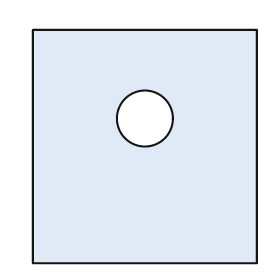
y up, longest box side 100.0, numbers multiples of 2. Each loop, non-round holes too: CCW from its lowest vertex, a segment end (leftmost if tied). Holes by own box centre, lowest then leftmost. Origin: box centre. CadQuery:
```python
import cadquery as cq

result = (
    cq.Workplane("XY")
    .moveTo(-48.0, -50.0)
    .lineTo(48.0, -50.0)
    .lineTo(48.0, 50.0)
    .lineTo(-48.0, 50.0)
    .close()
    .moveTo(0.0, 12.0)
    .circle(12.0)
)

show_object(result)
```